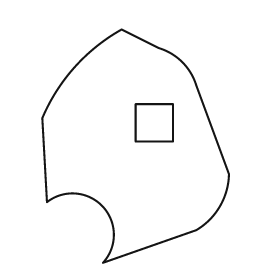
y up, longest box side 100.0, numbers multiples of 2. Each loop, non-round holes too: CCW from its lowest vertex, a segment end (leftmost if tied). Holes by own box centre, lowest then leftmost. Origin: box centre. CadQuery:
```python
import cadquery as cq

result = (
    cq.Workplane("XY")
    .moveTo(-14.0, -50.0)
    .lineTo(26.0, -36.0)
    .threePointArc((36.0, -26.0), (40.0, -12.0))
    .lineTo(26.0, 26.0)
    .threePointArc((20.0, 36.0), (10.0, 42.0))
    .lineTo(-6.0, 50.0)
    .threePointArc((-26.0, 34.0), (-40.0, 12.0))
    .lineTo(-38.0, -24.0)
    .threePointArc((-14.0, -26.0), (-14.0, -50.0))
    .close()
    .moveTo(0.0, 2.0)
    .lineTo(16.0, 2.0)
    .lineTo(16.0, 18.0)
    .lineTo(0.0, 18.0)
    .close()
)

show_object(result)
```